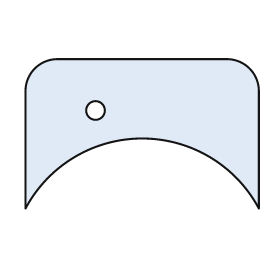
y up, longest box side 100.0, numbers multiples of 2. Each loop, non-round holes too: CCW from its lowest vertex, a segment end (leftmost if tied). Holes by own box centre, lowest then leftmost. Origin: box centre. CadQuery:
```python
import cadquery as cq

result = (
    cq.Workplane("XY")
    .moveTo(-50.0, -32.0)
    .threePointArc((0.0, -2.0), (50.0, -32.0))
    .lineTo(50.0, 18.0)
    .threePointArc((46.0, 28.0), (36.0, 32.0))
    .lineTo(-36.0, 32.0)
    .threePointArc((-46.0, 28.0), (-50.0, 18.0))
    .close()
    .moveTo(-20.0, 10.0)
    .circle(4.0)
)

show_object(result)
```